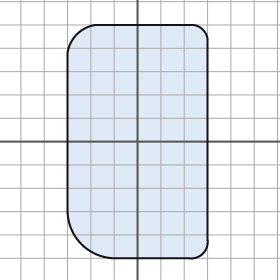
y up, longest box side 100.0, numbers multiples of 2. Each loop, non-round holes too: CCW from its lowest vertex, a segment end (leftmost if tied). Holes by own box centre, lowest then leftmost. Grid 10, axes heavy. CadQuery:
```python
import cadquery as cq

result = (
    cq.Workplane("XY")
    .moveTo(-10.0, -50.0)
    .lineTo(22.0, -50.0)
    .threePointArc((28.0, -48.0), (30.0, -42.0))
    .lineTo(30.0, 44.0)
    .threePointArc((28.0, 48.0), (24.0, 50.0))
    .lineTo(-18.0, 50.0)
    .threePointArc((-26.0, 46.0), (-30.0, 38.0))
    .lineTo(-30.0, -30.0)
    .threePointArc((-24.0, -44.0), (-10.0, -50.0))
    .close()
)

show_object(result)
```